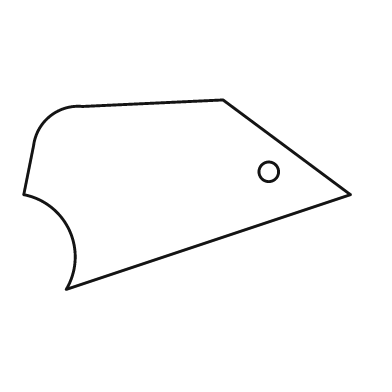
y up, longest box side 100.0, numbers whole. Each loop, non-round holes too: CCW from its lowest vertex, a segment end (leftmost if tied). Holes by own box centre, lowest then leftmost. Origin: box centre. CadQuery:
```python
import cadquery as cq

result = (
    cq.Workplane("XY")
    .moveTo(-37.0, -29.0)
    .lineTo(50.0, 0.0)
    .lineTo(11.0, 29.0)
    .lineTo(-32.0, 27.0)
    .threePointArc((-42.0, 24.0), (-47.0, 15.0))
    .lineTo(-50.0, 0.0)
    .threePointArc((-36.0, -11.0), (-37.0, -29.0))
    .close()
    .moveTo(25.0, 7.0)
    .circle(3.0)
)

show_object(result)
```